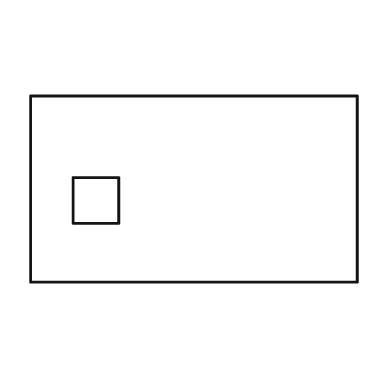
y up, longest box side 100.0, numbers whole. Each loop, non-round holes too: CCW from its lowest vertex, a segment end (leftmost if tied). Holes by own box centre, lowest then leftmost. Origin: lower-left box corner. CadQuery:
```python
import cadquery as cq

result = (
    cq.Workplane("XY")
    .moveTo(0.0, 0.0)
    .lineTo(100.0, 0.0)
    .lineTo(100.0, 57.0)
    .lineTo(0.0, 57.0)
    .close()
    .moveTo(13.0, 18.0)
    .lineTo(27.0, 18.0)
    .lineTo(27.0, 32.0)
    .lineTo(13.0, 32.0)
    .close()
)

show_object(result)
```